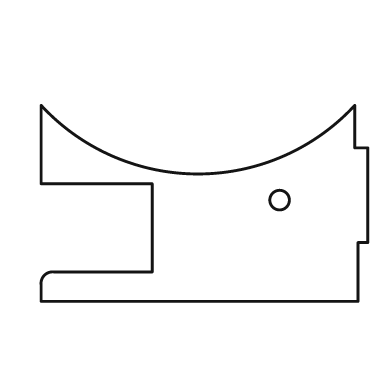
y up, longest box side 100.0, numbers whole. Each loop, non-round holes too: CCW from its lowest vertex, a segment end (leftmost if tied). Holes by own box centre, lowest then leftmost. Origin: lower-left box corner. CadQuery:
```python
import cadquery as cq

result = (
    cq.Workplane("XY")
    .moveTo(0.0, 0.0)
    .lineTo(97.0, 0.0)
    .lineTo(97.0, 18.0)
    .lineTo(100.0, 18.0)
    .lineTo(100.0, 47.0)
    .lineTo(96.0, 47.0)
    .lineTo(96.0, 60.0)
    .threePointArc((48.0, 39.0), (0.0, 60.0))
    .lineTo(0.0, 36.0)
    .lineTo(34.0, 36.0)
    .lineTo(34.0, 9.0)
    .lineTo(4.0, 9.0)
    .threePointArc((1.0, 8.0), (0.0, 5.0))
    .close()
    .moveTo(73.0, 31.0)
    .circle(3.0)
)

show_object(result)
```